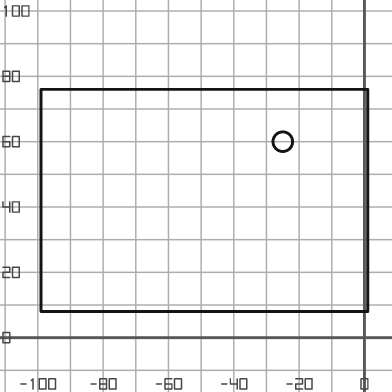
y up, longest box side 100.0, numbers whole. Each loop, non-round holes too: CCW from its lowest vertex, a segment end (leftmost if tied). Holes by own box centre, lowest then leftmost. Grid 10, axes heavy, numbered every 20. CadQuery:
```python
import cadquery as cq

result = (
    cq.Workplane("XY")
    .moveTo(-99.0, 8.0)
    .lineTo(1.0, 8.0)
    .lineTo(1.0, 76.0)
    .lineTo(-99.0, 76.0)
    .close()
    .moveTo(-25.0, 60.0)
    .circle(3.0)
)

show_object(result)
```